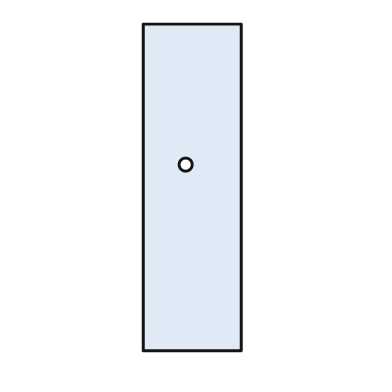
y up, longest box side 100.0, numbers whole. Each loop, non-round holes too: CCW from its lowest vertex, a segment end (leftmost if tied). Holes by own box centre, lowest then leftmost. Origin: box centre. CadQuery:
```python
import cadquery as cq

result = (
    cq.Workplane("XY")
    .moveTo(-15.0, -50.0)
    .lineTo(15.0, -50.0)
    .lineTo(15.0, 50.0)
    .lineTo(-15.0, 50.0)
    .close()
    .moveTo(-2.0, 7.0)
    .circle(2.0)
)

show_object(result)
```